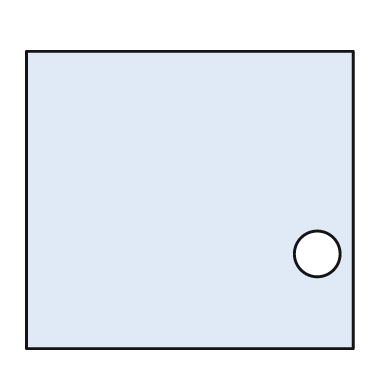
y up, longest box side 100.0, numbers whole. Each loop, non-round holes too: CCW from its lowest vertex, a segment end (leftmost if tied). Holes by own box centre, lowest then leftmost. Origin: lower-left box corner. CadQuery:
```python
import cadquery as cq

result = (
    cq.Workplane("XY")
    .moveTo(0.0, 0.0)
    .lineTo(100.0, 0.0)
    .lineTo(100.0, 91.0)
    .lineTo(0.0, 91.0)
    .close()
    .moveTo(89.0, 29.0)
    .circle(7.0)
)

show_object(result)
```